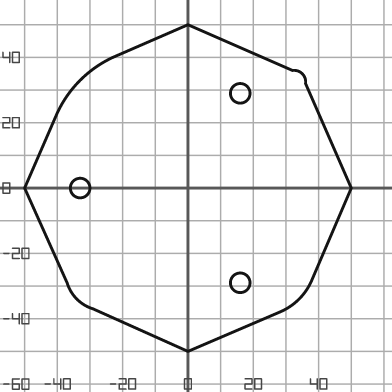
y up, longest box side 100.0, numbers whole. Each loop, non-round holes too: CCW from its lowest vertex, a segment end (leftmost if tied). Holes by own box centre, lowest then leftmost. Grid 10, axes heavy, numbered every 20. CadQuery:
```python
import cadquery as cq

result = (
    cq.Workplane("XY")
    .moveTo(0.0, -50.0)
    .lineTo(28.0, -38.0)
    .threePointArc((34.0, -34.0), (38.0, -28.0))
    .lineTo(50.0, 0.0)
    .lineTo(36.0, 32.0)
    .threePointArc((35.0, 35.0), (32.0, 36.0))
    .lineTo(0.0, 50.0)
    .lineTo(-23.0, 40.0)
    .threePointArc((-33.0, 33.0), (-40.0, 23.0))
    .lineTo(-50.0, 0.0)
    .lineTo(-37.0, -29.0)
    .threePointArc((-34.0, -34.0), (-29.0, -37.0))
    .close()
    .moveTo(16.0, -29.0)
    .circle(3.0)
    .moveTo(-33.0, 0.0)
    .circle(3.0)
    .moveTo(16.0, 29.0)
    .circle(3.0)
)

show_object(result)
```